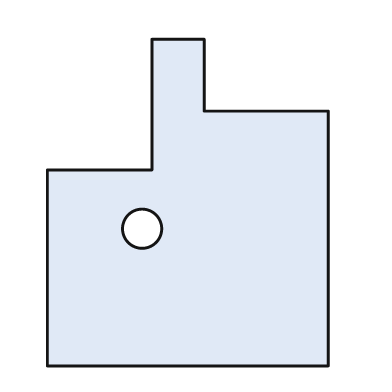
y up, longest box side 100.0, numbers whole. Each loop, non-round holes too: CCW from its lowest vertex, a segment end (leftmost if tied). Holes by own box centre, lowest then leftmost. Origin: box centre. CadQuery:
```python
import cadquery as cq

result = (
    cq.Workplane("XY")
    .moveTo(-43.0, -50.0)
    .lineTo(43.0, -50.0)
    .lineTo(43.0, 28.0)
    .lineTo(5.0, 28.0)
    .lineTo(5.0, 50.0)
    .lineTo(-11.0, 50.0)
    .lineTo(-11.0, 10.0)
    .lineTo(-43.0, 10.0)
    .close()
    .moveTo(-14.0, -8.0)
    .circle(6.0)
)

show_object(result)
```